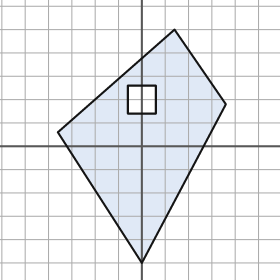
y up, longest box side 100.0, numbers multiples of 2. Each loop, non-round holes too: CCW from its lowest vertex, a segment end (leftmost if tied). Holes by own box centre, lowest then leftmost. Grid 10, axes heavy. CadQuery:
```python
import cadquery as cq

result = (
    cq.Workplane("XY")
    .moveTo(0.0, -50.0)
    .lineTo(36.0, 18.0)
    .lineTo(14.0, 50.0)
    .lineTo(-36.0, 6.0)
    .close()
    .moveTo(-6.0, 14.0)
    .lineTo(6.0, 14.0)
    .lineTo(6.0, 26.0)
    .lineTo(-6.0, 26.0)
    .close()
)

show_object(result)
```